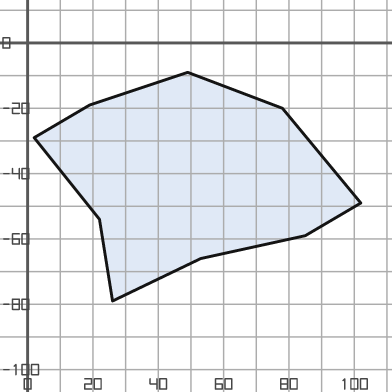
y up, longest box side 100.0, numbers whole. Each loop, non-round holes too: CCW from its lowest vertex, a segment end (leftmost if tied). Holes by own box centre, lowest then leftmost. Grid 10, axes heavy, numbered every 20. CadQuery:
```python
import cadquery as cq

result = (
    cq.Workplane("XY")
    .moveTo(26.0, -79.0)
    .lineTo(53.0, -66.0)
    .lineTo(85.0, -59.0)
    .lineTo(102.0, -49.0)
    .lineTo(78.0, -20.0)
    .lineTo(49.0, -9.0)
    .lineTo(19.0, -19.0)
    .lineTo(2.0, -29.0)
    .lineTo(22.0, -54.0)
    .close()
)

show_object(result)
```